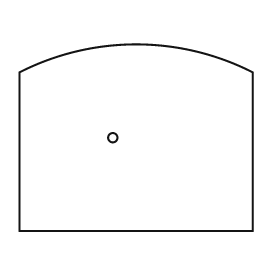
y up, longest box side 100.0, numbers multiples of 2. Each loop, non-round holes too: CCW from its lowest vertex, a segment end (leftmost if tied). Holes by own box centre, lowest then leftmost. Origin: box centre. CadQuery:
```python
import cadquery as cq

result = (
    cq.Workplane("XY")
    .moveTo(-50.0, -40.0)
    .lineTo(50.0, -40.0)
    .lineTo(50.0, 28.0)
    .threePointArc((0.0, 40.0), (-50.0, 28.0))
    .close()
    .moveTo(-10.0, 0.0)
    .circle(2.0)
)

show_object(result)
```